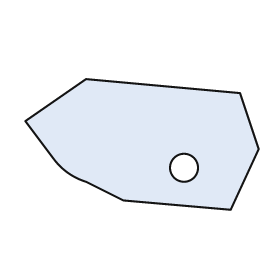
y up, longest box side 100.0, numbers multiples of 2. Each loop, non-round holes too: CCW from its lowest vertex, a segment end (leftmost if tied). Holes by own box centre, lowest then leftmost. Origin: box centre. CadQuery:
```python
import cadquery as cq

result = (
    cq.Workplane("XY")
    .moveTo(38.0, -28.0)
    .lineTo(50.0, -2.0)
    .lineTo(42.0, 22.0)
    .lineTo(-24.0, 28.0)
    .lineTo(-50.0, 10.0)
    .lineTo(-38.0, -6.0)
    .threePointArc((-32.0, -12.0), (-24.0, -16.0))
    .lineTo(-8.0, -24.0)
    .close()
    .moveTo(18.0, -10.0)
    .circle(6.0)
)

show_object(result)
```